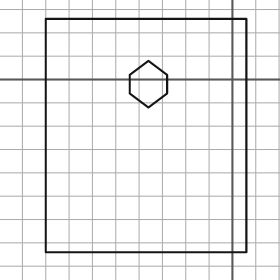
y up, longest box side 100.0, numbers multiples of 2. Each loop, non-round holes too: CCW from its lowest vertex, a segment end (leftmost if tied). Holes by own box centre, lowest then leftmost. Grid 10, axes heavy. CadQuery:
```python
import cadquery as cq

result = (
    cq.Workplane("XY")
    .moveTo(-80.0, -74.0)
    .lineTo(6.0, -74.0)
    .lineTo(6.0, 26.0)
    .lineTo(-80.0, 26.0)
    .close()
    .moveTo(-36.0, -12.0)
    .lineTo(-28.0, -6.0)
    .lineTo(-28.0, 2.0)
    .lineTo(-36.0, 8.0)
    .lineTo(-44.0, 2.0)
    .lineTo(-44.0, -6.0)
    .close()
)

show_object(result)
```